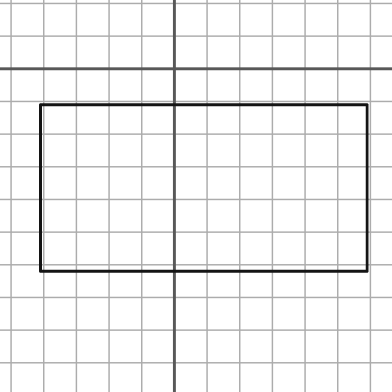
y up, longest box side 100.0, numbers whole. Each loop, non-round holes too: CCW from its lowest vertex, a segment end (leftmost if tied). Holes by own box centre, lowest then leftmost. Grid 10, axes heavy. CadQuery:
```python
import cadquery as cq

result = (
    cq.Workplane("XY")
    .moveTo(-41.0, -62.0)
    .lineTo(59.0, -62.0)
    .lineTo(59.0, -11.0)
    .lineTo(-41.0, -11.0)
    .close()
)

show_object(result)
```